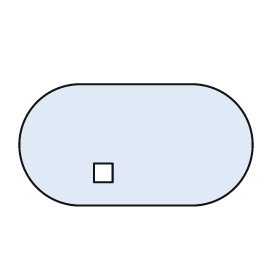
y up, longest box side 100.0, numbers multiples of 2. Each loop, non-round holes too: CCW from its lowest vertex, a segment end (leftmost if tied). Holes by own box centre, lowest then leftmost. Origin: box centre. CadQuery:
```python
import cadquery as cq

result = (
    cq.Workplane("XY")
    .moveTo(-24.0, -26.0)
    .lineTo(24.0, -26.0)
    .threePointArc((50.0, 0.0), (24.0, 26.0))
    .lineTo(-24.0, 26.0)
    .threePointArc((-50.0, 0.0), (-24.0, -26.0))
    .close()
    .moveTo(-18.0, -16.0)
    .lineTo(-10.0, -16.0)
    .lineTo(-10.0, -8.0)
    .lineTo(-18.0, -8.0)
    .close()
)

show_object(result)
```